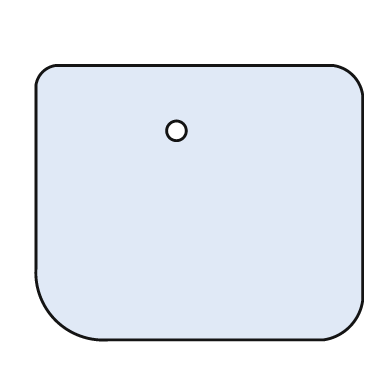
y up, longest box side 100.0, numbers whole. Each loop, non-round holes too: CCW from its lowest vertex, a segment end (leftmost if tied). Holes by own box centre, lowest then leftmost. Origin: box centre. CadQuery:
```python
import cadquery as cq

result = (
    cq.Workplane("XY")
    .moveTo(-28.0, -42.0)
    .lineTo(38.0, -42.0)
    .threePointArc((46.0, -38.0), (50.0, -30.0))
    .lineTo(50.0, 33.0)
    .threePointArc((47.0, 39.0), (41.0, 42.0))
    .lineTo(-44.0, 42.0)
    .threePointArc((-48.0, 40.0), (-50.0, 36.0))
    .lineTo(-50.0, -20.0)
    .threePointArc((-44.0, -36.0), (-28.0, -42.0))
    .close()
    .moveTo(-7.0, 22.0)
    .circle(3.0)
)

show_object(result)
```